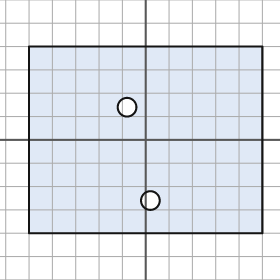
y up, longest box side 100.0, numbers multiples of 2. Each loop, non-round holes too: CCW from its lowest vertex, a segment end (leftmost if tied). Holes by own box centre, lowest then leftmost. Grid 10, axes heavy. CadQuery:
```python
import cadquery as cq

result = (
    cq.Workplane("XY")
    .moveTo(-50.0, -40.0)
    .lineTo(50.0, -40.0)
    .lineTo(50.0, 40.0)
    .lineTo(-50.0, 40.0)
    .close()
    .moveTo(2.0, -26.0)
    .circle(4.0)
    .moveTo(-8.0, 14.0)
    .circle(4.0)
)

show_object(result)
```